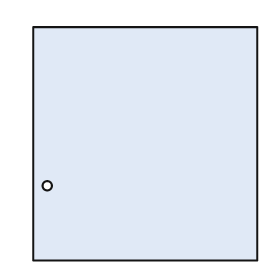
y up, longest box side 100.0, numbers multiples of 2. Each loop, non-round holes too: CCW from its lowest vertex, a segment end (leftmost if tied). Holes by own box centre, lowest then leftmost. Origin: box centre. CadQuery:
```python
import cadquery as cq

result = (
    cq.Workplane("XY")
    .moveTo(-48.0, -50.0)
    .lineTo(48.0, -50.0)
    .lineTo(48.0, 50.0)
    .lineTo(-48.0, 50.0)
    .close()
    .moveTo(-42.0, -18.0)
    .circle(2.0)
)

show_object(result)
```